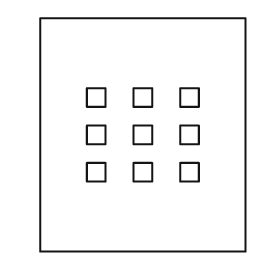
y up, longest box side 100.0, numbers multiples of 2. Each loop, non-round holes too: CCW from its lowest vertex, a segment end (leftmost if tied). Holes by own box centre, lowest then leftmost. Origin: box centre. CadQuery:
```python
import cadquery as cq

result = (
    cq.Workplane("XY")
    .moveTo(-44.0, -50.0)
    .lineTo(44.0, -50.0)
    .lineTo(44.0, 50.0)
    .lineTo(-44.0, 50.0)
    .close()
    .moveTo(-24.0, -20.0)
    .lineTo(-16.0, -20.0)
    .lineTo(-16.0, -12.0)
    .lineTo(-24.0, -12.0)
    .close()
    .moveTo(-4.0, -20.0)
    .lineTo(4.0, -20.0)
    .lineTo(4.0, -12.0)
    .lineTo(-4.0, -12.0)
    .close()
    .moveTo(16.0, -20.0)
    .lineTo(24.0, -20.0)
    .lineTo(24.0, -12.0)
    .lineTo(16.0, -12.0)
    .close()
    .moveTo(-24.0, -4.0)
    .lineTo(-16.0, -4.0)
    .lineTo(-16.0, 4.0)
    .lineTo(-24.0, 4.0)
    .close()
    .moveTo(-4.0, -4.0)
    .lineTo(4.0, -4.0)
    .lineTo(4.0, 4.0)
    .lineTo(-4.0, 4.0)
    .close()
    .moveTo(16.0, -4.0)
    .lineTo(24.0, -4.0)
    .lineTo(24.0, 4.0)
    .lineTo(16.0, 4.0)
    .close()
    .moveTo(-24.0, 12.0)
    .lineTo(-16.0, 12.0)
    .lineTo(-16.0, 20.0)
    .lineTo(-24.0, 20.0)
    .close()
    .moveTo(-4.0, 12.0)
    .lineTo(4.0, 12.0)
    .lineTo(4.0, 20.0)
    .lineTo(-4.0, 20.0)
    .close()
    .moveTo(16.0, 12.0)
    .lineTo(24.0, 12.0)
    .lineTo(24.0, 20.0)
    .lineTo(16.0, 20.0)
    .close()
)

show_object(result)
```